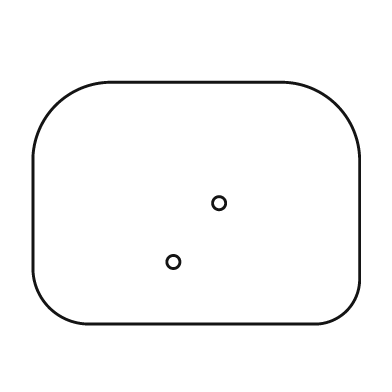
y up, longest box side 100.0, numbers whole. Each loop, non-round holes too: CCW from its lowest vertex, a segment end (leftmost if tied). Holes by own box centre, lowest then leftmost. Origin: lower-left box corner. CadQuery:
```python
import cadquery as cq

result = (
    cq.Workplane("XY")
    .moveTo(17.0, 0.0)
    .lineTo(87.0, 0.0)
    .threePointArc((96.0, 4.0), (100.0, 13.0))
    .lineTo(100.0, 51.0)
    .threePointArc((93.0, 67.0), (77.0, 74.0))
    .lineTo(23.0, 74.0)
    .threePointArc((7.0, 67.0), (0.0, 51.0))
    .lineTo(0.0, 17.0)
    .threePointArc((5.0, 5.0), (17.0, 0.0))
    .close()
    .moveTo(43.0, 19.0)
    .circle(2.0)
    .moveTo(57.0, 37.0)
    .circle(2.0)
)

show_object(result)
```